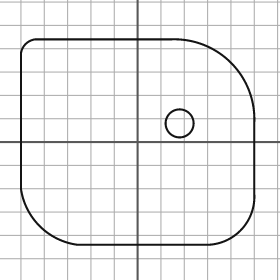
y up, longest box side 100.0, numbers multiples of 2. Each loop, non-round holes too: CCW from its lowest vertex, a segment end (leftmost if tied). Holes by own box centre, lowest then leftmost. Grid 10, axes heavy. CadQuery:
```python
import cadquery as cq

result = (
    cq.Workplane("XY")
    .moveTo(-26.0, -44.0)
    .lineTo(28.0, -44.0)
    .threePointArc((44.0, -38.0), (50.0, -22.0))
    .lineTo(50.0, 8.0)
    .threePointArc((40.0, 34.0), (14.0, 44.0))
    .lineTo(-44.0, 44.0)
    .threePointArc((-48.0, 42.0), (-50.0, 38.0))
    .lineTo(-50.0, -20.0)
    .threePointArc((-42.0, -36.0), (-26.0, -44.0))
    .close()
    .moveTo(18.0, 8.0)
    .circle(6.0)
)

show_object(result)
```